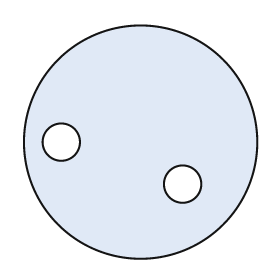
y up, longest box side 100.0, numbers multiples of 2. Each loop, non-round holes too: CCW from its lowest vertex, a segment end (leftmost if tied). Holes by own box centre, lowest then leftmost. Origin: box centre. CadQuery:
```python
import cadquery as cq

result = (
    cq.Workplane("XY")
    .moveTo(0.0, 0.0)
    .circle(50.0)
    .moveTo(18.0, -18.0)
    .circle(8.0)
    .moveTo(-34.0, 0.0)
    .circle(8.0)
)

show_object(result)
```